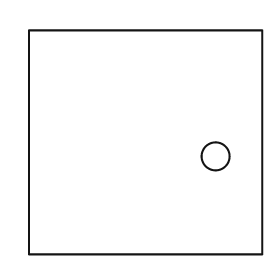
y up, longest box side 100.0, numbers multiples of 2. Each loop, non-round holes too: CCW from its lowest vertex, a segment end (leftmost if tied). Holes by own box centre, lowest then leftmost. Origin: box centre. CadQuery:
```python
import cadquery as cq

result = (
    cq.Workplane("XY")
    .moveTo(-50.0, -48.0)
    .lineTo(50.0, -48.0)
    .lineTo(50.0, 48.0)
    .lineTo(-50.0, 48.0)
    .close()
    .moveTo(30.0, -6.0)
    .circle(6.0)
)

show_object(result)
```